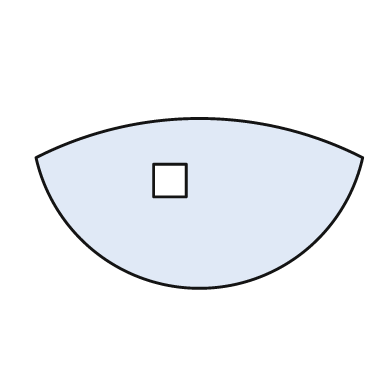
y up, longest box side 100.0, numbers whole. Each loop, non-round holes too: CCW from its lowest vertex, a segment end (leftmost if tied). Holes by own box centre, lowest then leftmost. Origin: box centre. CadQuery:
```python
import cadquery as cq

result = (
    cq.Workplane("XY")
    .moveTo(-50.0, 14.0)
    .threePointArc((0.0, -26.0), (50.0, 14.0))
    .threePointArc((0.0, 26.0), (-50.0, 14.0))
    .close()
    .moveTo(-14.0, 2.0)
    .lineTo(-4.0, 2.0)
    .lineTo(-4.0, 12.0)
    .lineTo(-14.0, 12.0)
    .close()
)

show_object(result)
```